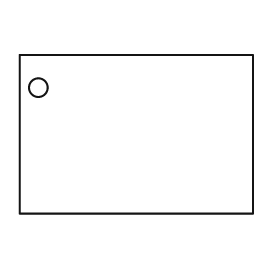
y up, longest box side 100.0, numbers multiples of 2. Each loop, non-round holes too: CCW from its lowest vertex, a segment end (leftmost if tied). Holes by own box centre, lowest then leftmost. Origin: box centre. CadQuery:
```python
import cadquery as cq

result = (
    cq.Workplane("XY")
    .moveTo(-50.0, -34.0)
    .lineTo(50.0, -34.0)
    .lineTo(50.0, 34.0)
    .lineTo(-50.0, 34.0)
    .close()
    .moveTo(-42.0, 20.0)
    .circle(4.0)
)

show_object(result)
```